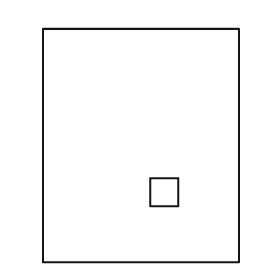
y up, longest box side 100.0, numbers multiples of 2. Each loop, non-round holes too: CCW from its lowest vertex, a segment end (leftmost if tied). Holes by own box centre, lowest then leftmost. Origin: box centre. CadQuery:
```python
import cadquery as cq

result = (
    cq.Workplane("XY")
    .moveTo(-42.0, -50.0)
    .lineTo(42.0, -50.0)
    .lineTo(42.0, 50.0)
    .lineTo(-42.0, 50.0)
    .close()
    .moveTo(4.0, -26.0)
    .lineTo(16.0, -26.0)
    .lineTo(16.0, -14.0)
    .lineTo(4.0, -14.0)
    .close()
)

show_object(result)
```